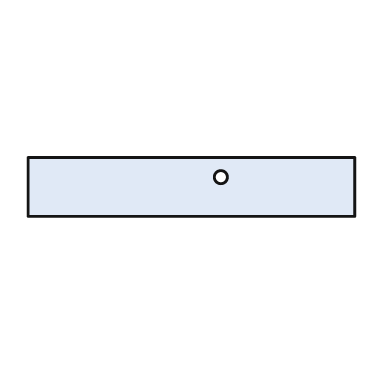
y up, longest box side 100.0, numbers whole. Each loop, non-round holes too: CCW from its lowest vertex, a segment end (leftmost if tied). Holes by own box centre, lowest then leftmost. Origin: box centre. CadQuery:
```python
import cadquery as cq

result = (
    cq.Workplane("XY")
    .moveTo(-50.0, -9.0)
    .lineTo(50.0, -9.0)
    .lineTo(50.0, 9.0)
    .lineTo(-50.0, 9.0)
    .close()
    .moveTo(9.0, 3.0)
    .circle(2.0)
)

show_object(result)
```